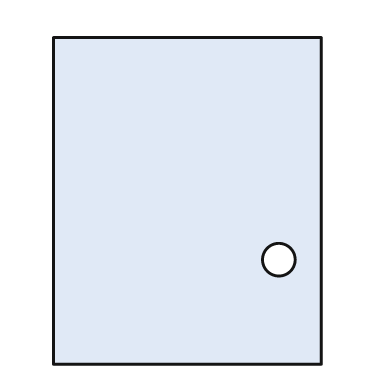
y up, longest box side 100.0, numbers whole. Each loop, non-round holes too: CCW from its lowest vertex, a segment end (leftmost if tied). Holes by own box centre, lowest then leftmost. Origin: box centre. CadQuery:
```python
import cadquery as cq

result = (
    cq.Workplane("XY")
    .moveTo(-41.0, -50.0)
    .lineTo(41.0, -50.0)
    .lineTo(41.0, 50.0)
    .lineTo(-41.0, 50.0)
    .close()
    .moveTo(28.0, -18.0)
    .circle(5.0)
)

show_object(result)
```